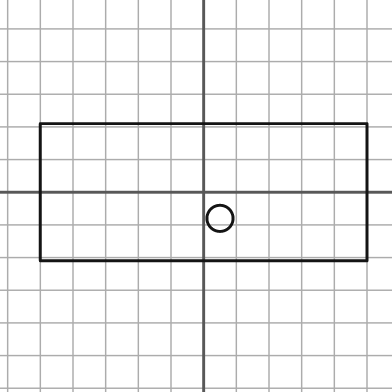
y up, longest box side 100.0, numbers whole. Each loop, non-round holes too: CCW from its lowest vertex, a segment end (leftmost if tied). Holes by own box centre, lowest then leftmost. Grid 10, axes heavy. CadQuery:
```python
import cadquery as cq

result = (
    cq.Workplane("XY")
    .moveTo(-50.0, -21.0)
    .lineTo(50.0, -21.0)
    .lineTo(50.0, 21.0)
    .lineTo(-50.0, 21.0)
    .close()
    .moveTo(5.0, -8.0)
    .circle(4.0)
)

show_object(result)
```